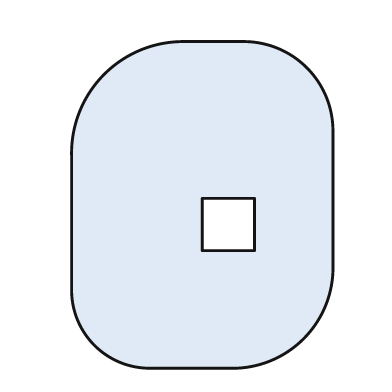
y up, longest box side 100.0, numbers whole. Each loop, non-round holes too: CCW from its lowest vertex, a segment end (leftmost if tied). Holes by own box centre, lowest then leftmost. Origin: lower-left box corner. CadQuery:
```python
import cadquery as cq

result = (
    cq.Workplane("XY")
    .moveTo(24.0, 0.0)
    .lineTo(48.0, 0.0)
    .threePointArc((71.0, 9.0), (80.0, 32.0))
    .lineTo(80.0, 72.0)
    .threePointArc((72.0, 92.0), (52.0, 100.0))
    .lineTo(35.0, 100.0)
    .threePointArc((10.0, 90.0), (0.0, 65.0))
    .lineTo(0.0, 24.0)
    .threePointArc((7.0, 7.0), (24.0, 0.0))
    .close()
    .moveTo(40.0, 36.0)
    .lineTo(56.0, 36.0)
    .lineTo(56.0, 52.0)
    .lineTo(40.0, 52.0)
    .close()
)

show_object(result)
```